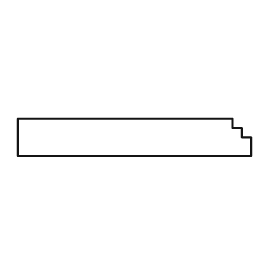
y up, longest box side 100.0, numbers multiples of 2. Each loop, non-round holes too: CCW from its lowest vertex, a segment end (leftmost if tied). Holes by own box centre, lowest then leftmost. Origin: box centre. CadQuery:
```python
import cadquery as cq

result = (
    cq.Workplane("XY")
    .moveTo(-50.0, -8.0)
    .lineTo(50.0, -8.0)
    .lineTo(50.0, 0.0)
    .lineTo(46.0, 0.0)
    .lineTo(46.0, 4.0)
    .lineTo(42.0, 4.0)
    .lineTo(42.0, 8.0)
    .lineTo(-50.0, 8.0)
    .close()
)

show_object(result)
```